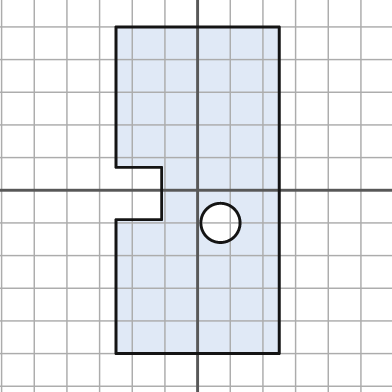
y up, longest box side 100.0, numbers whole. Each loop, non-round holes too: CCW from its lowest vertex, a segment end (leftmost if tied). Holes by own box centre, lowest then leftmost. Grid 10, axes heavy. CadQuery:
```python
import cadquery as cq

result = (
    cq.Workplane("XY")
    .moveTo(-25.0, -50.0)
    .lineTo(25.0, -50.0)
    .lineTo(25.0, 50.0)
    .lineTo(-25.0, 50.0)
    .lineTo(-25.0, 7.0)
    .lineTo(-11.0, 7.0)
    .lineTo(-11.0, -9.0)
    .lineTo(-25.0, -9.0)
    .close()
    .moveTo(7.0, -10.0)
    .circle(6.0)
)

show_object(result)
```